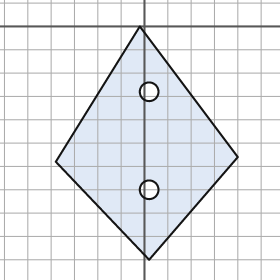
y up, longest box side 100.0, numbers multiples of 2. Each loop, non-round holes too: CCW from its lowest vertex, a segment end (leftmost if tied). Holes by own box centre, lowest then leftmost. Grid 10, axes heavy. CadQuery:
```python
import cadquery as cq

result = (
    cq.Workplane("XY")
    .moveTo(2.0, -100.0)
    .lineTo(40.0, -56.0)
    .lineTo(-2.0, 0.0)
    .lineTo(-38.0, -58.0)
    .close()
    .moveTo(2.0, -70.0)
    .circle(4.0)
    .moveTo(2.0, -28.0)
    .circle(4.0)
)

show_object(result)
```